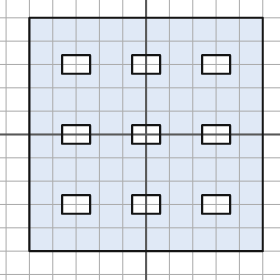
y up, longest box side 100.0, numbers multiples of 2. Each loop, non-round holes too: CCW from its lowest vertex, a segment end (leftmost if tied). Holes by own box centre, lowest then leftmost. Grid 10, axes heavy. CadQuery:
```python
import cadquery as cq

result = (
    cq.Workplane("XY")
    .moveTo(-50.0, -50.0)
    .lineTo(50.0, -50.0)
    .lineTo(50.0, 50.0)
    .lineTo(-50.0, 50.0)
    .close()
    .moveTo(-36.0, -34.0)
    .lineTo(-24.0, -34.0)
    .lineTo(-24.0, -26.0)
    .lineTo(-36.0, -26.0)
    .close()
    .moveTo(-6.0, -34.0)
    .lineTo(6.0, -34.0)
    .lineTo(6.0, -26.0)
    .lineTo(-6.0, -26.0)
    .close()
    .moveTo(24.0, -34.0)
    .lineTo(36.0, -34.0)
    .lineTo(36.0, -26.0)
    .lineTo(24.0, -26.0)
    .close()
    .moveTo(-36.0, -4.0)
    .lineTo(-24.0, -4.0)
    .lineTo(-24.0, 4.0)
    .lineTo(-36.0, 4.0)
    .close()
    .moveTo(-6.0, -4.0)
    .lineTo(6.0, -4.0)
    .lineTo(6.0, 4.0)
    .lineTo(-6.0, 4.0)
    .close()
    .moveTo(24.0, -4.0)
    .lineTo(36.0, -4.0)
    .lineTo(36.0, 4.0)
    .lineTo(24.0, 4.0)
    .close()
    .moveTo(-36.0, 26.0)
    .lineTo(-24.0, 26.0)
    .lineTo(-24.0, 34.0)
    .lineTo(-36.0, 34.0)
    .close()
    .moveTo(-6.0, 26.0)
    .lineTo(6.0, 26.0)
    .lineTo(6.0, 34.0)
    .lineTo(-6.0, 34.0)
    .close()
    .moveTo(24.0, 26.0)
    .lineTo(36.0, 26.0)
    .lineTo(36.0, 34.0)
    .lineTo(24.0, 34.0)
    .close()
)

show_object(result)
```